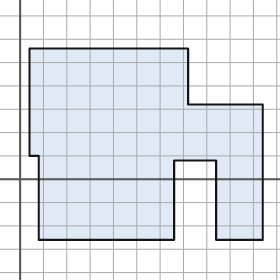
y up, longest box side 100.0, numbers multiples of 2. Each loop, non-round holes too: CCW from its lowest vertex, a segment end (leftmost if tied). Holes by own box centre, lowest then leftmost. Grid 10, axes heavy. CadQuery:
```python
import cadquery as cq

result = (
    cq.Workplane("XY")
    .moveTo(8.0, -26.0)
    .lineTo(66.0, -26.0)
    .lineTo(66.0, 8.0)
    .lineTo(84.0, 8.0)
    .lineTo(84.0, -26.0)
    .lineTo(104.0, -26.0)
    .lineTo(104.0, 32.0)
    .lineTo(72.0, 32.0)
    .lineTo(72.0, 56.0)
    .lineTo(4.0, 56.0)
    .lineTo(4.0, 10.0)
    .lineTo(8.0, 10.0)
    .close()
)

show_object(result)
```